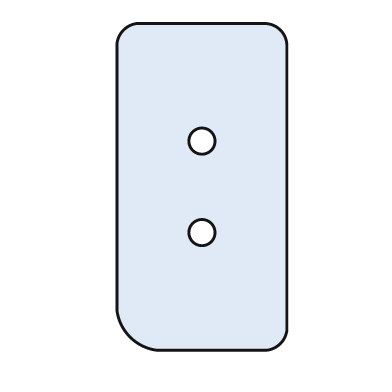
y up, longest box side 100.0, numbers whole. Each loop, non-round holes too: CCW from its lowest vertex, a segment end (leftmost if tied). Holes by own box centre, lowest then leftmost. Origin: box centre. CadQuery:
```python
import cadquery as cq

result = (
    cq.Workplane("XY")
    .moveTo(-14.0, -50.0)
    .lineTo(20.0, -50.0)
    .threePointArc((24.0, -48.0), (26.0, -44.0))
    .lineTo(26.0, 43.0)
    .threePointArc((24.0, 48.0), (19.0, 50.0))
    .lineTo(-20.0, 50.0)
    .threePointArc((-24.0, 48.0), (-26.0, 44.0))
    .lineTo(-26.0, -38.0)
    .threePointArc((-22.0, -46.0), (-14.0, -50.0))
    .close()
    .moveTo(0.0, -14.0)
    .circle(4.0)
    .moveTo(0.0, 14.0)
    .circle(4.0)
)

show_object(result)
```